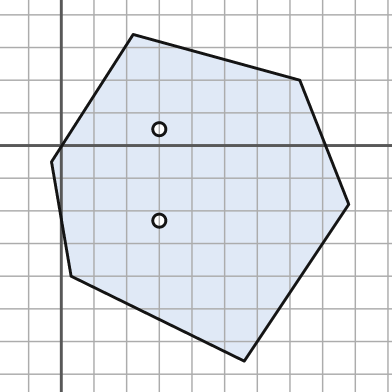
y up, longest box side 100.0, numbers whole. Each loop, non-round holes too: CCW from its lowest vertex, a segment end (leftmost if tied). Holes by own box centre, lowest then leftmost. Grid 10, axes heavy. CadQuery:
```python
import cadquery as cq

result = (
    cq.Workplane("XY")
    .moveTo(56.0, -66.0)
    .lineTo(88.0, -18.0)
    .lineTo(73.0, 20.0)
    .lineTo(22.0, 34.0)
    .lineTo(-3.0, -5.0)
    .lineTo(3.0, -40.0)
    .close()
    .moveTo(30.0, -23.0)
    .circle(2.0)
    .moveTo(30.0, 5.0)
    .circle(2.0)
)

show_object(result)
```